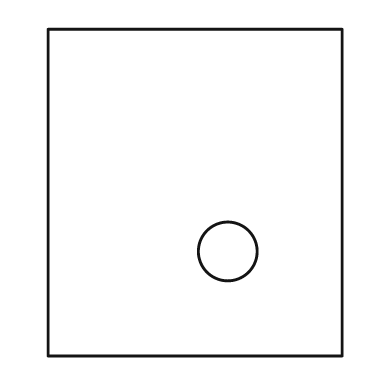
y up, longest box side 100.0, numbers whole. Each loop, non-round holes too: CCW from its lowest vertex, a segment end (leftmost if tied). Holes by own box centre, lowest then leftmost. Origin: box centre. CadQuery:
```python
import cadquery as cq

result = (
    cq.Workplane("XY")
    .moveTo(-45.0, -50.0)
    .lineTo(45.0, -50.0)
    .lineTo(45.0, 50.0)
    .lineTo(-45.0, 50.0)
    .close()
    .moveTo(10.0, -18.0)
    .circle(9.0)
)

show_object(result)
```